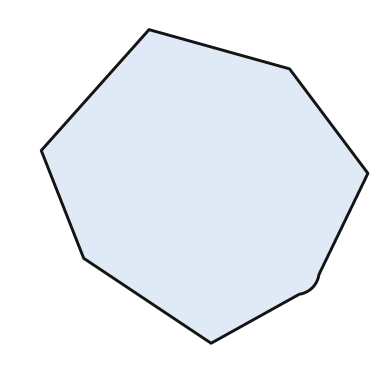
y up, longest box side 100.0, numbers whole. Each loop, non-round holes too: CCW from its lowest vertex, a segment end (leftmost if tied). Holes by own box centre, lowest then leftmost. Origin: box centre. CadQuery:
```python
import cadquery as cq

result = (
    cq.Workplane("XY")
    .moveTo(2.0, -48.0)
    .lineTo(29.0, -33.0)
    .threePointArc((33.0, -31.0), (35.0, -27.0))
    .lineTo(50.0, 4.0)
    .lineTo(26.0, 36.0)
    .lineTo(-17.0, 48.0)
    .lineTo(-50.0, 11.0)
    .lineTo(-37.0, -22.0)
    .close()
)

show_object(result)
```